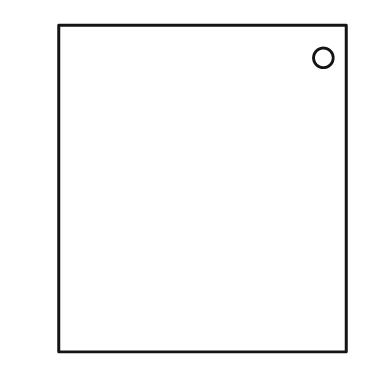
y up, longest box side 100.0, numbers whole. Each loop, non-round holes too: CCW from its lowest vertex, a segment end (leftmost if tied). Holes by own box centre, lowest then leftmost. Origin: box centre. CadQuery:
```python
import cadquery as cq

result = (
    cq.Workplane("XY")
    .moveTo(-44.0, -50.0)
    .lineTo(44.0, -50.0)
    .lineTo(44.0, 50.0)
    .lineTo(-44.0, 50.0)
    .close()
    .moveTo(37.0, 40.0)
    .circle(3.0)
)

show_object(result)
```